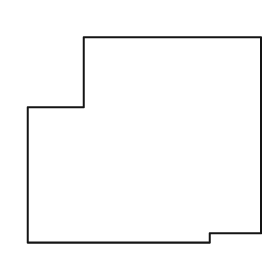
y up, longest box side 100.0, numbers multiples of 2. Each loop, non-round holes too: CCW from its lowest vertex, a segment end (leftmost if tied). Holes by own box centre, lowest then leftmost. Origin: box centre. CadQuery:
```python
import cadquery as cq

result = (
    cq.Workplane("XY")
    .moveTo(-50.0, -44.0)
    .lineTo(28.0, -44.0)
    .lineTo(28.0, -40.0)
    .lineTo(50.0, -40.0)
    .lineTo(50.0, 44.0)
    .lineTo(-26.0, 44.0)
    .lineTo(-26.0, 14.0)
    .lineTo(-50.0, 14.0)
    .close()
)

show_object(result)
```